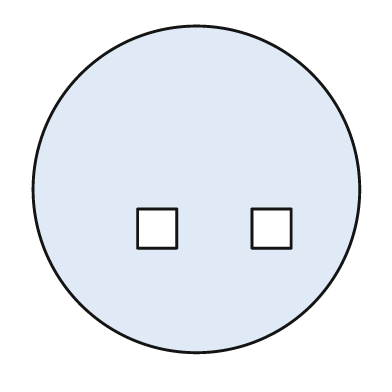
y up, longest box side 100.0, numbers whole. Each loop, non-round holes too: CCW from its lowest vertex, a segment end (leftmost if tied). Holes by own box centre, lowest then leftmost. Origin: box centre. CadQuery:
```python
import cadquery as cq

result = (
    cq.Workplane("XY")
    .moveTo(0.0, 0.0)
    .circle(50.0)
    .moveTo(-18.0, -18.0)
    .lineTo(-6.0, -18.0)
    .lineTo(-6.0, -6.0)
    .lineTo(-18.0, -6.0)
    .close()
    .moveTo(17.0, -18.0)
    .lineTo(29.0, -18.0)
    .lineTo(29.0, -6.0)
    .lineTo(17.0, -6.0)
    .close()
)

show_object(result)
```